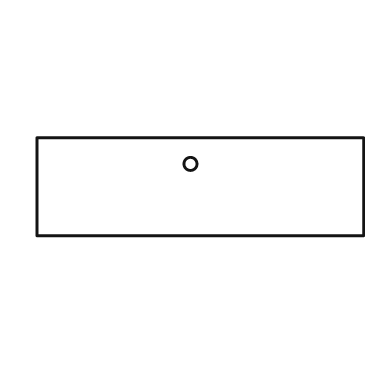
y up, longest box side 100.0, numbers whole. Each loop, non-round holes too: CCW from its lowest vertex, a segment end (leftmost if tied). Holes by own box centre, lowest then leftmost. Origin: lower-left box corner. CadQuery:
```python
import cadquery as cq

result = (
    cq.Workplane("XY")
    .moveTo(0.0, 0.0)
    .lineTo(100.0, 0.0)
    .lineTo(100.0, 30.0)
    .lineTo(0.0, 30.0)
    .close()
    .moveTo(47.0, 22.0)
    .circle(2.0)
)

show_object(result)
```